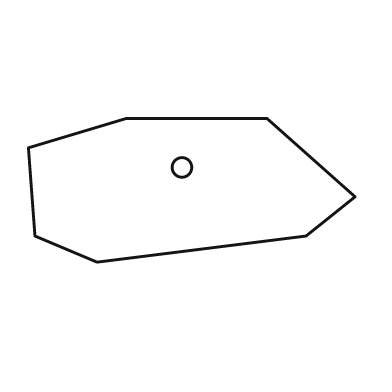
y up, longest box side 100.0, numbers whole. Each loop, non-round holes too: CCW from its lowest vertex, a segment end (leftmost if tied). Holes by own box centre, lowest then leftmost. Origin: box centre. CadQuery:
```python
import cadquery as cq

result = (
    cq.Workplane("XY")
    .moveTo(-29.0, -22.0)
    .lineTo(35.0, -14.0)
    .lineTo(50.0, -2.0)
    .lineTo(23.0, 22.0)
    .lineTo(-20.0, 22.0)
    .lineTo(-50.0, 13.0)
    .lineTo(-48.0, -14.0)
    .close()
    .moveTo(-3.0, 7.0)
    .circle(3.0)
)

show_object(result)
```